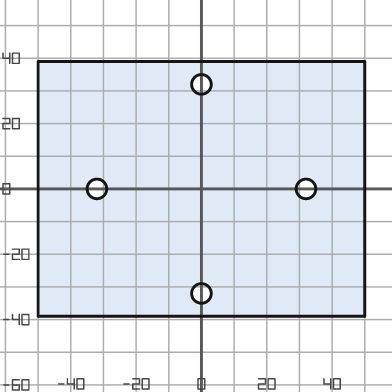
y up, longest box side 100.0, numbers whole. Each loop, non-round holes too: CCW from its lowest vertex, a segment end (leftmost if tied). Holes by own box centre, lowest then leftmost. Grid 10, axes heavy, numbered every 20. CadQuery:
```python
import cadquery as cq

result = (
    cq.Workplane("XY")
    .moveTo(-50.0, -39.0)
    .lineTo(50.0, -39.0)
    .lineTo(50.0, 39.0)
    .lineTo(-50.0, 39.0)
    .close()
    .moveTo(0.0, -32.0)
    .circle(3.0)
    .moveTo(-32.0, 0.0)
    .circle(3.0)
    .moveTo(32.0, 0.0)
    .circle(3.0)
    .moveTo(0.0, 32.0)
    .circle(3.0)
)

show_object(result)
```